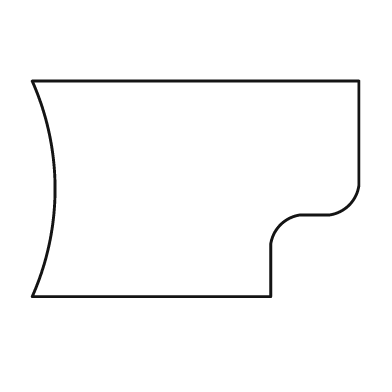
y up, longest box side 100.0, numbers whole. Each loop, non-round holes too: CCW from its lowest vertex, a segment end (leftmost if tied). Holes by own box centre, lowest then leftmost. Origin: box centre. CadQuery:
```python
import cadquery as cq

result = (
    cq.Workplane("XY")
    .moveTo(-50.0, -33.0)
    .lineTo(23.0, -33.0)
    .lineTo(23.0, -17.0)
    .threePointArc((26.0, -11.0), (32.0, -8.0))
    .lineTo(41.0, -8.0)
    .threePointArc((47.0, -5.0), (50.0, 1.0))
    .lineTo(50.0, 33.0)
    .lineTo(-50.0, 33.0)
    .threePointArc((-43.0, 0.0), (-50.0, -33.0))
    .close()
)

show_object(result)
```